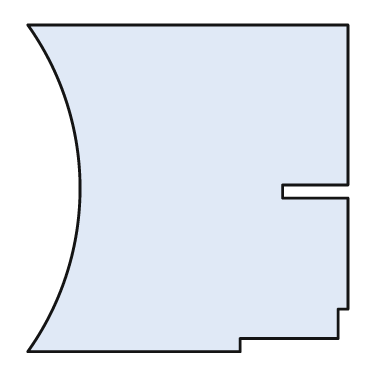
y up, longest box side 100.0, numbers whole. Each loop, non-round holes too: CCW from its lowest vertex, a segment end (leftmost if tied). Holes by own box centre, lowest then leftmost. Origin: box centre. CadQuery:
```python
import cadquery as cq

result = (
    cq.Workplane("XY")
    .moveTo(-49.0, -50.0)
    .lineTo(16.0, -50.0)
    .lineTo(16.0, -46.0)
    .lineTo(46.0, -46.0)
    .lineTo(46.0, -37.0)
    .lineTo(49.0, -37.0)
    .lineTo(49.0, -3.0)
    .lineTo(29.0, -3.0)
    .lineTo(29.0, 1.0)
    .lineTo(49.0, 1.0)
    .lineTo(49.0, 50.0)
    .lineTo(-49.0, 50.0)
    .threePointArc((-33.0, 0.0), (-49.0, -50.0))
    .close()
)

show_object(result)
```